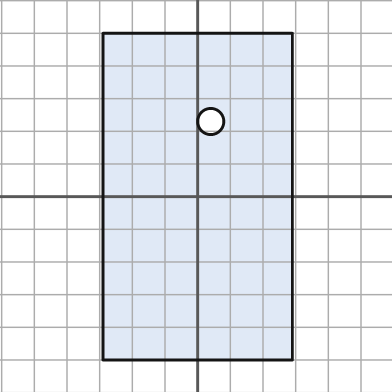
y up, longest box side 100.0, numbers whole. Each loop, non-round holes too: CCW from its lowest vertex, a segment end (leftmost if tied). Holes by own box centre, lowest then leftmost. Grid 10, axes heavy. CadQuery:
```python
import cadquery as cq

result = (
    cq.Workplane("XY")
    .moveTo(-29.0, -50.0)
    .lineTo(29.0, -50.0)
    .lineTo(29.0, 50.0)
    .lineTo(-29.0, 50.0)
    .close()
    .moveTo(4.0, 23.0)
    .circle(4.0)
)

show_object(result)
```